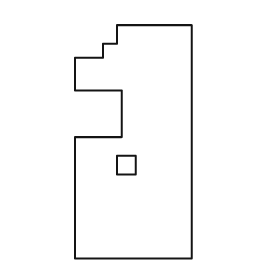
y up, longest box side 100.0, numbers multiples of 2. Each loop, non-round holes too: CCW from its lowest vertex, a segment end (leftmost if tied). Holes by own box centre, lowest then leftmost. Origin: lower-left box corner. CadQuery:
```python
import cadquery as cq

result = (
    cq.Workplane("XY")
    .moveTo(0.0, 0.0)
    .lineTo(50.0, 0.0)
    .lineTo(50.0, 100.0)
    .lineTo(18.0, 100.0)
    .lineTo(18.0, 92.0)
    .lineTo(12.0, 92.0)
    .lineTo(12.0, 86.0)
    .lineTo(0.0, 86.0)
    .lineTo(0.0, 72.0)
    .lineTo(20.0, 72.0)
    .lineTo(20.0, 52.0)
    .lineTo(0.0, 52.0)
    .close()
    .moveTo(18.0, 36.0)
    .lineTo(26.0, 36.0)
    .lineTo(26.0, 44.0)
    .lineTo(18.0, 44.0)
    .close()
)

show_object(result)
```